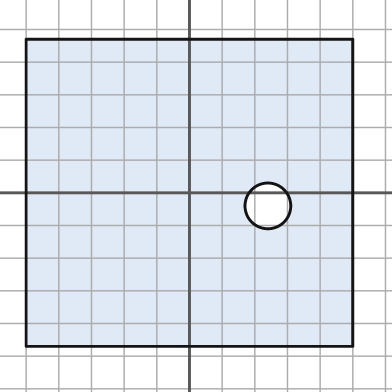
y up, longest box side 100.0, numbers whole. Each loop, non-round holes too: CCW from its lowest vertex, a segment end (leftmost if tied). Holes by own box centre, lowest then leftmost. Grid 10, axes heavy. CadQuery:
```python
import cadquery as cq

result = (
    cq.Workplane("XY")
    .moveTo(-50.0, -47.0)
    .lineTo(50.0, -47.0)
    .lineTo(50.0, 47.0)
    .lineTo(-50.0, 47.0)
    .close()
    .moveTo(24.0, -4.0)
    .circle(7.0)
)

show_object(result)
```